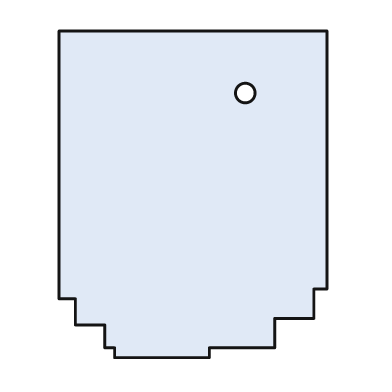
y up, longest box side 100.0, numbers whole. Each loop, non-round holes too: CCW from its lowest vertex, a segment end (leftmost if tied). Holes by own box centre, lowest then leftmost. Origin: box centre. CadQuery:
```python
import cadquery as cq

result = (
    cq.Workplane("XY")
    .moveTo(-24.0, -50.0)
    .lineTo(5.0, -50.0)
    .lineTo(5.0, -47.0)
    .lineTo(25.0, -47.0)
    .lineTo(25.0, -38.0)
    .lineTo(37.0, -38.0)
    .lineTo(37.0, -29.0)
    .lineTo(41.0, -29.0)
    .lineTo(41.0, 50.0)
    .lineTo(-41.0, 50.0)
    .lineTo(-41.0, -32.0)
    .lineTo(-36.0, -32.0)
    .lineTo(-36.0, -40.0)
    .lineTo(-27.0, -40.0)
    .lineTo(-27.0, -47.0)
    .lineTo(-24.0, -47.0)
    .close()
    .moveTo(16.0, 31.0)
    .circle(3.0)
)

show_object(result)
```